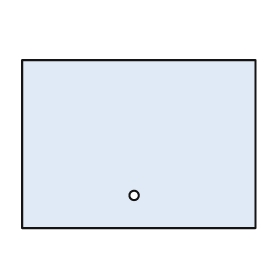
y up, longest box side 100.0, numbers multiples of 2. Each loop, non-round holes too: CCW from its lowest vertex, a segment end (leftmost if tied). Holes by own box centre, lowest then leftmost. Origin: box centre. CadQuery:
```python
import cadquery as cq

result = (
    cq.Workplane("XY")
    .moveTo(-50.0, -36.0)
    .lineTo(50.0, -36.0)
    .lineTo(50.0, 36.0)
    .lineTo(-50.0, 36.0)
    .close()
    .moveTo(-2.0, -22.0)
    .circle(2.0)
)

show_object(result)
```